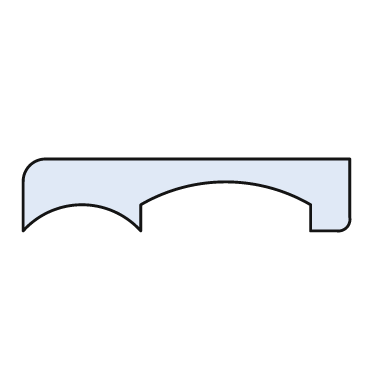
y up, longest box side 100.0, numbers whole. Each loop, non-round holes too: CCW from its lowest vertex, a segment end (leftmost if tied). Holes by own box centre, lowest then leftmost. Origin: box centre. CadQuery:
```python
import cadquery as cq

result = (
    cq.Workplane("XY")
    .moveTo(-50.0, -11.0)
    .threePointArc((-32.0, -3.0), (-14.0, -11.0))
    .lineTo(-14.0, -3.0)
    .threePointArc((12.0, 4.0), (38.0, -3.0))
    .lineTo(38.0, -11.0)
    .lineTo(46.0, -11.0)
    .threePointArc((49.0, -10.0), (50.0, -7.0))
    .lineTo(50.0, 11.0)
    .lineTo(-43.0, 11.0)
    .threePointArc((-48.0, 9.0), (-50.0, 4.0))
    .close()
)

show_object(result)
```